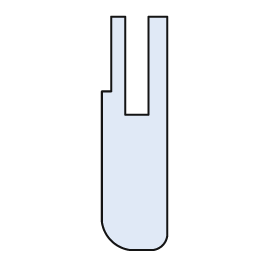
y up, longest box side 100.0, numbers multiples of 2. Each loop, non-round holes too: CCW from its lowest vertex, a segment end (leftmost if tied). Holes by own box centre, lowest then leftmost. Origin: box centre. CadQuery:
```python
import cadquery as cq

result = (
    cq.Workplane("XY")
    .moveTo(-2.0, -50.0)
    .lineTo(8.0, -50.0)
    .threePointArc((12.0, -48.0), (14.0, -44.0))
    .lineTo(14.0, 50.0)
    .lineTo(6.0, 50.0)
    .lineTo(6.0, 8.0)
    .lineTo(-4.0, 8.0)
    .lineTo(-4.0, 50.0)
    .lineTo(-10.0, 50.0)
    .lineTo(-10.0, 18.0)
    .lineTo(-14.0, 18.0)
    .lineTo(-14.0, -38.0)
    .threePointArc((-10.0, -46.0), (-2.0, -50.0))
    .close()
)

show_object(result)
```